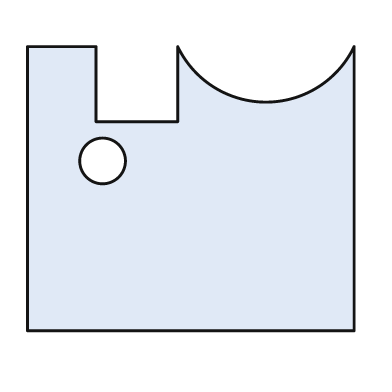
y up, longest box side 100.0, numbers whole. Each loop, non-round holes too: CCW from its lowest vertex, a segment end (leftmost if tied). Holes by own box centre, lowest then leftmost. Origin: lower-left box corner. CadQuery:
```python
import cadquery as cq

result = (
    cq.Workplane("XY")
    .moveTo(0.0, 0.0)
    .lineTo(100.0, 0.0)
    .lineTo(100.0, 87.0)
    .threePointArc((73.0, 70.0), (46.0, 87.0))
    .lineTo(46.0, 64.0)
    .lineTo(21.0, 64.0)
    .lineTo(21.0, 87.0)
    .lineTo(0.0, 87.0)
    .close()
    .moveTo(23.0, 52.0)
    .circle(7.0)
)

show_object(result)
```